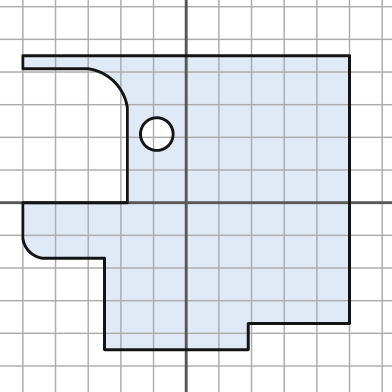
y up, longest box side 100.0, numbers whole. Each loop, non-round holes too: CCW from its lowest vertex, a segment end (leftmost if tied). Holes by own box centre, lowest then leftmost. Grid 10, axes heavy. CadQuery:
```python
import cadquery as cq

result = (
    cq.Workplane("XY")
    .moveTo(-25.0, -45.0)
    .lineTo(19.0, -45.0)
    .lineTo(19.0, -37.0)
    .lineTo(50.0, -37.0)
    .lineTo(50.0, 45.0)
    .lineTo(-50.0, 45.0)
    .lineTo(-50.0, 41.0)
    .lineTo(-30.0, 41.0)
    .threePointArc((-22.0, 37.0), (-18.0, 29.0))
    .lineTo(-18.0, 0.0)
    .lineTo(-50.0, 0.0)
    .lineTo(-50.0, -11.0)
    .threePointArc((-48.0, -15.0), (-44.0, -17.0))
    .lineTo(-25.0, -17.0)
    .close()
    .moveTo(-9.0, 21.0)
    .circle(5.0)
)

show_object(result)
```